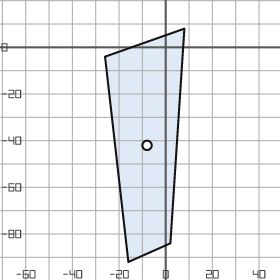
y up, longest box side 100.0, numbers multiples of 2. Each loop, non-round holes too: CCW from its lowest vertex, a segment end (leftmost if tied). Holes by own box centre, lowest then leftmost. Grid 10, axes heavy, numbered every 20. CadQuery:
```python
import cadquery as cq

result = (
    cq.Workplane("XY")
    .moveTo(-16.0, -92.0)
    .lineTo(2.0, -84.0)
    .lineTo(8.0, 8.0)
    .lineTo(-26.0, -4.0)
    .close()
    .moveTo(-8.0, -42.0)
    .circle(2.0)
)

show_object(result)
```